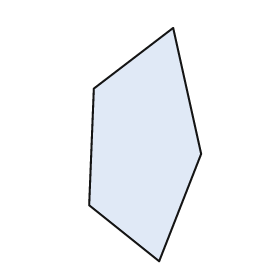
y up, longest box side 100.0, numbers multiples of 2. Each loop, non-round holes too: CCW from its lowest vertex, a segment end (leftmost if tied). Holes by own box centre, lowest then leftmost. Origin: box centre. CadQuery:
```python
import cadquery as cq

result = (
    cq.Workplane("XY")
    .moveTo(6.0, -50.0)
    .lineTo(24.0, -4.0)
    .lineTo(12.0, 50.0)
    .lineTo(-22.0, 24.0)
    .lineTo(-24.0, -26.0)
    .close()
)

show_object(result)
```